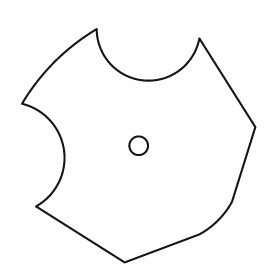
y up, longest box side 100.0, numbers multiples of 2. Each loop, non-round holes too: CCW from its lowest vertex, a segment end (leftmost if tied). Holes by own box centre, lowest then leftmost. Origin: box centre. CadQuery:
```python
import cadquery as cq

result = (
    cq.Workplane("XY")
    .moveTo(-6.0, -50.0)
    .lineTo(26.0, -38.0)
    .threePointArc((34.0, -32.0), (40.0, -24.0))
    .lineTo(50.0, 8.0)
    .lineTo(26.0, 46.0)
    .threePointArc((2.0, 28.0), (-18.0, 50.0))
    .threePointArc((-36.0, 36.0), (-50.0, 18.0))
    .threePointArc((-32.0, -2.0), (-44.0, -26.0))
    .close()
    .moveTo(0.0, 0.0)
    .circle(4.0)
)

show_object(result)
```